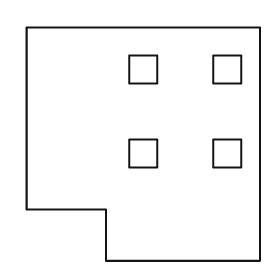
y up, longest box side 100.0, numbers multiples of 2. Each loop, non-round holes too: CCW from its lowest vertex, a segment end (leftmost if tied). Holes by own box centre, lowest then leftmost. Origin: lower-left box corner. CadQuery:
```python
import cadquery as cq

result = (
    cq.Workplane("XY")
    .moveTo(34.0, 0.0)
    .lineTo(100.0, 0.0)
    .lineTo(100.0, 100.0)
    .lineTo(0.0, 100.0)
    .lineTo(0.0, 22.0)
    .lineTo(34.0, 22.0)
    .close()
    .moveTo(44.0, 40.0)
    .lineTo(56.0, 40.0)
    .lineTo(56.0, 52.0)
    .lineTo(44.0, 52.0)
    .close()
    .moveTo(80.0, 40.0)
    .lineTo(92.0, 40.0)
    .lineTo(92.0, 52.0)
    .lineTo(80.0, 52.0)
    .close()
    .moveTo(44.0, 76.0)
    .lineTo(56.0, 76.0)
    .lineTo(56.0, 88.0)
    .lineTo(44.0, 88.0)
    .close()
    .moveTo(80.0, 76.0)
    .lineTo(92.0, 76.0)
    .lineTo(92.0, 88.0)
    .lineTo(80.0, 88.0)
    .close()
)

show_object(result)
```